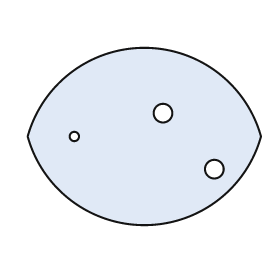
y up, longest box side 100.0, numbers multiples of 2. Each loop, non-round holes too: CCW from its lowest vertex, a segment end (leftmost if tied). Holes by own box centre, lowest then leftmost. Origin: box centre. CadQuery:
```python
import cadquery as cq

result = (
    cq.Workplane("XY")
    .moveTo(-50.0, 0.0)
    .threePointArc((0.0, -38.0), (50.0, 0.0))
    .threePointArc((0.0, 38.0), (-50.0, 0.0))
    .close()
    .moveTo(30.0, -14.0)
    .circle(4.0)
    .moveTo(-30.0, 0.0)
    .circle(2.0)
    .moveTo(8.0, 10.0)
    .circle(4.0)
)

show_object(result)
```